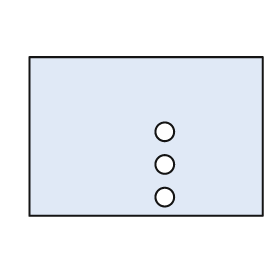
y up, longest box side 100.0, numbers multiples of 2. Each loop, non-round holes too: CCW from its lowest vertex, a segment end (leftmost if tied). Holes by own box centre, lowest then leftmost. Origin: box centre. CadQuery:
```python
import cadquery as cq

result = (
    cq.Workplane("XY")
    .moveTo(-50.0, -34.0)
    .lineTo(50.0, -34.0)
    .lineTo(50.0, 34.0)
    .lineTo(-50.0, 34.0)
    .close()
    .moveTo(8.0, -26.0)
    .circle(4.0)
    .moveTo(8.0, -12.0)
    .circle(4.0)
    .moveTo(8.0, 2.0)
    .circle(4.0)
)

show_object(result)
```